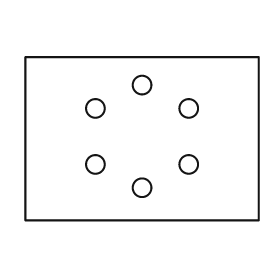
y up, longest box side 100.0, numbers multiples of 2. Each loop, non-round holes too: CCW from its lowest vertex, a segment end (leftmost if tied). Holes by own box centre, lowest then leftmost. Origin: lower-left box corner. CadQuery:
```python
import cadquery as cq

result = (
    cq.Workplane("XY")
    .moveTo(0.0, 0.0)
    .lineTo(100.0, 0.0)
    .lineTo(100.0, 70.0)
    .lineTo(0.0, 70.0)
    .close()
    .moveTo(50.0, 14.0)
    .circle(4.0)
    .moveTo(30.0, 24.0)
    .circle(4.0)
    .moveTo(70.0, 24.0)
    .circle(4.0)
    .moveTo(30.0, 48.0)
    .circle(4.0)
    .moveTo(70.0, 48.0)
    .circle(4.0)
    .moveTo(50.0, 58.0)
    .circle(4.0)
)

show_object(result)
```